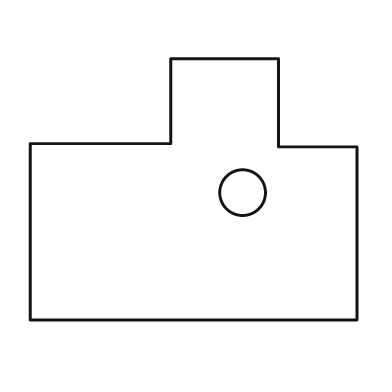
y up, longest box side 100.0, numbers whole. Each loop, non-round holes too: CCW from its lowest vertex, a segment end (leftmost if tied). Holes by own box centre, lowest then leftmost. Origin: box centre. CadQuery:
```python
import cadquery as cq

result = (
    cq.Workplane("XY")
    .moveTo(-50.0, -40.0)
    .lineTo(50.0, -40.0)
    .lineTo(50.0, 13.0)
    .lineTo(26.0, 13.0)
    .lineTo(26.0, 40.0)
    .lineTo(-7.0, 40.0)
    .lineTo(-7.0, 14.0)
    .lineTo(-50.0, 14.0)
    .close()
    .moveTo(15.0, -1.0)
    .circle(7.0)
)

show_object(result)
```